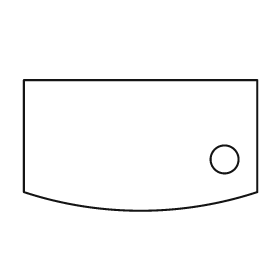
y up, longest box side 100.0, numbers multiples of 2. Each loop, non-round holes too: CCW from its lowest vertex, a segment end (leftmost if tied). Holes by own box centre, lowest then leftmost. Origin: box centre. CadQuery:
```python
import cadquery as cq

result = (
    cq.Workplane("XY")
    .moveTo(-50.0, -20.0)
    .threePointArc((0.0, -28.0), (50.0, -20.0))
    .lineTo(50.0, 28.0)
    .lineTo(-50.0, 28.0)
    .close()
    .moveTo(36.0, -6.0)
    .circle(6.0)
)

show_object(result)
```